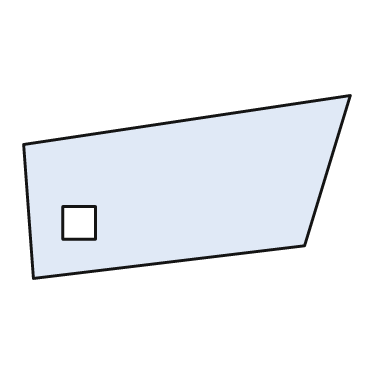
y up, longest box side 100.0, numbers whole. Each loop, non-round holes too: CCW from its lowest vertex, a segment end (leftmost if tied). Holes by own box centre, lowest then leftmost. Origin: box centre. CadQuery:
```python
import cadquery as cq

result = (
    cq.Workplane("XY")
    .moveTo(-47.0, -28.0)
    .lineTo(36.0, -18.0)
    .lineTo(50.0, 28.0)
    .lineTo(-50.0, 13.0)
    .close()
    .moveTo(-38.0, -16.0)
    .lineTo(-28.0, -16.0)
    .lineTo(-28.0, -6.0)
    .lineTo(-38.0, -6.0)
    .close()
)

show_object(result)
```